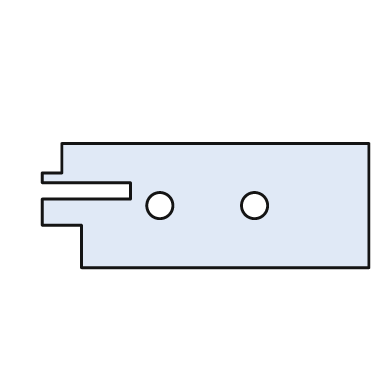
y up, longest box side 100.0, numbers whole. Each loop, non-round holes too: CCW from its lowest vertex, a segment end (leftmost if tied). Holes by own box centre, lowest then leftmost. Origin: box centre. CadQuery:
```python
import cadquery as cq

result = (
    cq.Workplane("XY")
    .moveTo(-38.0, -19.0)
    .lineTo(50.0, -19.0)
    .lineTo(50.0, 19.0)
    .lineTo(-44.0, 19.0)
    .lineTo(-44.0, 10.0)
    .lineTo(-50.0, 10.0)
    .lineTo(-50.0, 7.0)
    .lineTo(-23.0, 7.0)
    .lineTo(-23.0, 2.0)
    .lineTo(-50.0, 2.0)
    .lineTo(-50.0, -6.0)
    .lineTo(-38.0, -6.0)
    .close()
    .moveTo(-14.0, 0.0)
    .circle(4.0)
    .moveTo(15.0, 0.0)
    .circle(4.0)
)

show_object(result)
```